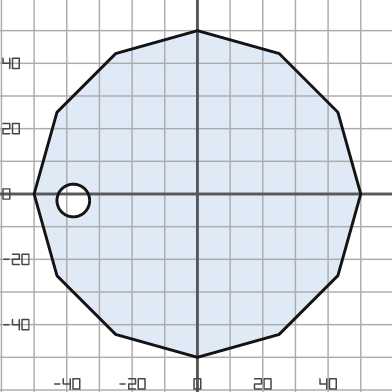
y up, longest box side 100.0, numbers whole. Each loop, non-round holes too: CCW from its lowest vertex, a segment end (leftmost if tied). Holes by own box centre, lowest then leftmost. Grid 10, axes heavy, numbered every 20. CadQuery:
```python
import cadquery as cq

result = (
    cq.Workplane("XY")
    .moveTo(0.0, -50.0)
    .lineTo(25.0, -43.0)
    .lineTo(43.0, -25.0)
    .lineTo(50.0, 0.0)
    .lineTo(43.0, 25.0)
    .lineTo(25.0, 43.0)
    .lineTo(0.0, 50.0)
    .lineTo(-25.0, 43.0)
    .lineTo(-43.0, 25.0)
    .lineTo(-50.0, 0.0)
    .lineTo(-43.0, -25.0)
    .lineTo(-25.0, -43.0)
    .close()
    .moveTo(-38.0, -2.0)
    .circle(5.0)
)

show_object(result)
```